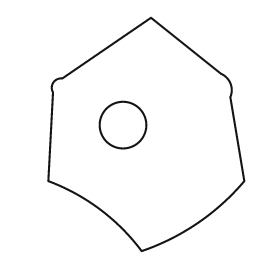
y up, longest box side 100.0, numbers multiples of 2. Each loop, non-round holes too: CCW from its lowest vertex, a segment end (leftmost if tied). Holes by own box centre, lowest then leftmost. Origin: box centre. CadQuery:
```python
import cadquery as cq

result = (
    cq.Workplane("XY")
    .moveTo(-2.0, -50.0)
    .threePointArc((22.0, -38.0), (42.0, -20.0))
    .lineTo(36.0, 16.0)
    .threePointArc((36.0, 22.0), (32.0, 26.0))
    .lineTo(2.0, 50.0)
    .lineTo(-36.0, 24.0)
    .threePointArc((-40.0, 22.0), (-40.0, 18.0))
    .lineTo(-42.0, -20.0)
    .threePointArc((-20.0, -32.0), (-2.0, -50.0))
    .close()
    .moveTo(-10.0, 4.0)
    .circle(10.0)
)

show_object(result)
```